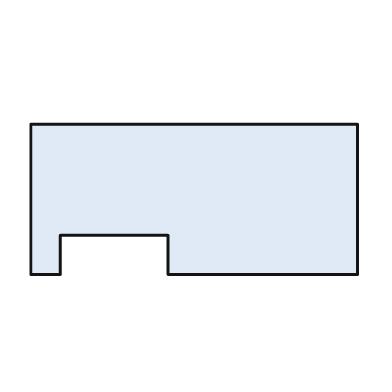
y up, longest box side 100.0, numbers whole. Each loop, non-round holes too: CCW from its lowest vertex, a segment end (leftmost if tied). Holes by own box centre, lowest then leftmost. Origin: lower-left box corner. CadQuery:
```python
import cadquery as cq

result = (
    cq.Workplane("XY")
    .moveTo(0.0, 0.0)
    .lineTo(9.0, 0.0)
    .lineTo(9.0, 12.0)
    .lineTo(42.0, 12.0)
    .lineTo(42.0, 0.0)
    .lineTo(100.0, 0.0)
    .lineTo(100.0, 46.0)
    .lineTo(0.0, 46.0)
    .close()
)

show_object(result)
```